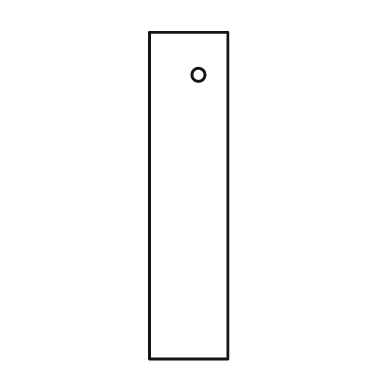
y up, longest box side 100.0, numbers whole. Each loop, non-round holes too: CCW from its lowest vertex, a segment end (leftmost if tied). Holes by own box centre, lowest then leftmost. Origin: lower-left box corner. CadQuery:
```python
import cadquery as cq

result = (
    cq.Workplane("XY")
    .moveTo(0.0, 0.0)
    .lineTo(24.0, 0.0)
    .lineTo(24.0, 100.0)
    .lineTo(0.0, 100.0)
    .close()
    .moveTo(15.0, 87.0)
    .circle(2.0)
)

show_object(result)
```